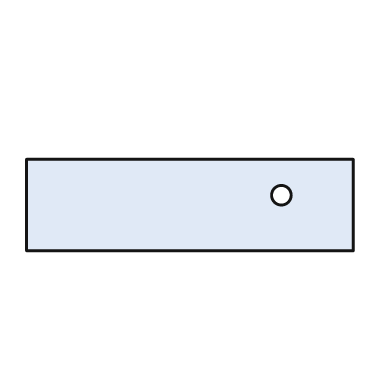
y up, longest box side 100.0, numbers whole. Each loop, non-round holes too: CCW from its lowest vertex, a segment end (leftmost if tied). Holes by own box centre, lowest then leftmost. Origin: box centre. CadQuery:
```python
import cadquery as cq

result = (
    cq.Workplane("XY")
    .moveTo(-50.0, -14.0)
    .lineTo(50.0, -14.0)
    .lineTo(50.0, 14.0)
    .lineTo(-50.0, 14.0)
    .close()
    .moveTo(28.0, 3.0)
    .circle(3.0)
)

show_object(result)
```